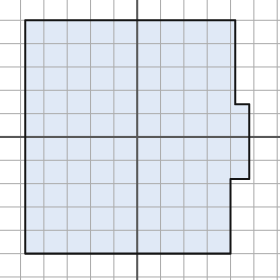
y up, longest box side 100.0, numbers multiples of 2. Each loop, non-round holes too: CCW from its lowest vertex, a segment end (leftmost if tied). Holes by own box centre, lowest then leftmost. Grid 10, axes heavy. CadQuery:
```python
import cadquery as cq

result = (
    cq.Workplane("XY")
    .moveTo(-48.0, -50.0)
    .lineTo(40.0, -50.0)
    .lineTo(40.0, -18.0)
    .lineTo(48.0, -18.0)
    .lineTo(48.0, 14.0)
    .lineTo(42.0, 14.0)
    .lineTo(42.0, 50.0)
    .lineTo(-48.0, 50.0)
    .close()
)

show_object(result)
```